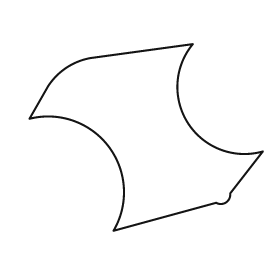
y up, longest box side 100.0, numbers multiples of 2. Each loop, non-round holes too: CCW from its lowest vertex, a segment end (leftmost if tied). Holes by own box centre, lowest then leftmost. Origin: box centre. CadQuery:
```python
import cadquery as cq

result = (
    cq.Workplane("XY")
    .moveTo(-14.0, -40.0)
    .lineTo(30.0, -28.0)
    .threePointArc((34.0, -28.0), (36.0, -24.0))
    .lineTo(50.0, -6.0)
    .threePointArc((18.0, 6.0), (20.0, 40.0))
    .lineTo(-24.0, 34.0)
    .threePointArc((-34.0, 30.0), (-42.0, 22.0))
    .lineTo(-50.0, 8.0)
    .threePointArc((-16.0, -4.0), (-14.0, -40.0))
    .close()
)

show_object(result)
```